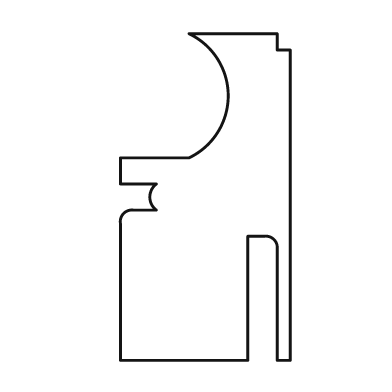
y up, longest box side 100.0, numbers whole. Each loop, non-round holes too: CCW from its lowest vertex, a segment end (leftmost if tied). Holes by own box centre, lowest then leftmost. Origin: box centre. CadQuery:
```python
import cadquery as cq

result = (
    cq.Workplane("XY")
    .moveTo(-26.0, -50.0)
    .lineTo(13.0, -50.0)
    .lineTo(13.0, -12.0)
    .lineTo(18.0, -12.0)
    .threePointArc((21.0, -13.0), (22.0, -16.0))
    .lineTo(22.0, -50.0)
    .lineTo(26.0, -50.0)
    .lineTo(26.0, 45.0)
    .lineTo(22.0, 45.0)
    .lineTo(22.0, 50.0)
    .lineTo(-5.0, 50.0)
    .threePointArc((7.0, 31.0), (-5.0, 12.0))
    .lineTo(-26.0, 12.0)
    .lineTo(-26.0, 4.0)
    .lineTo(-15.0, 4.0)
    .threePointArc((-17.0, 0.0), (-15.0, -4.0))
    .lineTo(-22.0, -4.0)
    .threePointArc((-25.0, -5.0), (-26.0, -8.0))
    .close()
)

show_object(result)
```